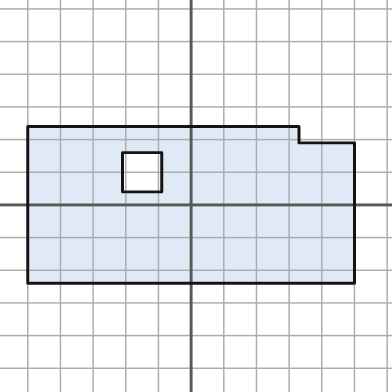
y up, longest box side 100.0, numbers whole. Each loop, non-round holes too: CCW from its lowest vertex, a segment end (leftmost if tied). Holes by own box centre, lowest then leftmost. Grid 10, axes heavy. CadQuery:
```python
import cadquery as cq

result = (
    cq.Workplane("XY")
    .moveTo(-50.0, -24.0)
    .lineTo(50.0, -24.0)
    .lineTo(50.0, 19.0)
    .lineTo(33.0, 19.0)
    .lineTo(33.0, 24.0)
    .lineTo(-50.0, 24.0)
    .close()
    .moveTo(-21.0, 4.0)
    .lineTo(-9.0, 4.0)
    .lineTo(-9.0, 16.0)
    .lineTo(-21.0, 16.0)
    .close()
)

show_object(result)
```